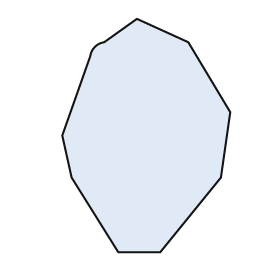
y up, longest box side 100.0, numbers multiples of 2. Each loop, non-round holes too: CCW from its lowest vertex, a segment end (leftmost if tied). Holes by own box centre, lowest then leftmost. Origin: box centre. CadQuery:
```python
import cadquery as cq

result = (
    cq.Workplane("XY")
    .moveTo(-12.0, -50.0)
    .lineTo(6.0, -50.0)
    .lineTo(32.0, -18.0)
    .lineTo(36.0, 10.0)
    .lineTo(18.0, 40.0)
    .lineTo(-4.0, 50.0)
    .lineTo(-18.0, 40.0)
    .threePointArc((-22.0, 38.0), (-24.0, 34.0))
    .lineTo(-36.0, 0.0)
    .lineTo(-32.0, -18.0)
    .close()
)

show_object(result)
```